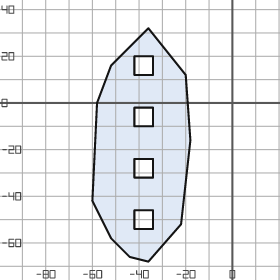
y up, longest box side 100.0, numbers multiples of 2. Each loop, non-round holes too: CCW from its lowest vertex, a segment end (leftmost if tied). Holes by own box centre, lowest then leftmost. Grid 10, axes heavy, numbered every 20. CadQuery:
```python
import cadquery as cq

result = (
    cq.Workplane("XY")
    .moveTo(-36.0, -68.0)
    .lineTo(-22.0, -52.0)
    .lineTo(-18.0, -16.0)
    .lineTo(-20.0, 12.0)
    .lineTo(-36.0, 32.0)
    .lineTo(-52.0, 16.0)
    .lineTo(-58.0, 0.0)
    .lineTo(-60.0, -42.0)
    .lineTo(-52.0, -58.0)
    .lineTo(-44.0, -66.0)
    .close()
    .moveTo(-42.0, -54.0)
    .lineTo(-34.0, -54.0)
    .lineTo(-34.0, -46.0)
    .lineTo(-42.0, -46.0)
    .close()
    .moveTo(-42.0, -32.0)
    .lineTo(-34.0, -32.0)
    .lineTo(-34.0, -24.0)
    .lineTo(-42.0, -24.0)
    .close()
    .moveTo(-42.0, -10.0)
    .lineTo(-34.0, -10.0)
    .lineTo(-34.0, -2.0)
    .lineTo(-42.0, -2.0)
    .close()
    .moveTo(-42.0, 12.0)
    .lineTo(-34.0, 12.0)
    .lineTo(-34.0, 20.0)
    .lineTo(-42.0, 20.0)
    .close()
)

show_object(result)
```